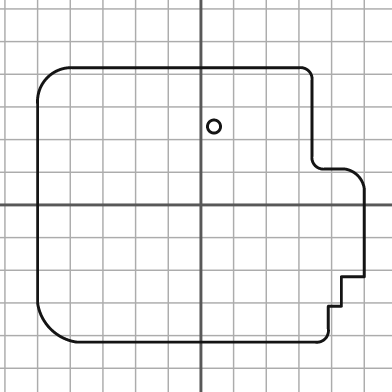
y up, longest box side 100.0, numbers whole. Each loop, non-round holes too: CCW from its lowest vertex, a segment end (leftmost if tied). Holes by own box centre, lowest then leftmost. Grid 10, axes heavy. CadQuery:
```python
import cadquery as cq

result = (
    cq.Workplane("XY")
    .moveTo(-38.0, -42.0)
    .lineTo(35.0, -42.0)
    .threePointArc((38.0, -41.0), (39.0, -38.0))
    .lineTo(39.0, -31.0)
    .lineTo(43.0, -31.0)
    .lineTo(43.0, -22.0)
    .lineTo(50.0, -22.0)
    .lineTo(50.0, 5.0)
    .threePointArc((48.0, 9.0), (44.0, 11.0))
    .lineTo(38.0, 11.0)
    .threePointArc((35.0, 12.0), (34.0, 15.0))
    .lineTo(34.0, 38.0)
    .threePointArc((33.0, 41.0), (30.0, 42.0))
    .lineTo(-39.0, 42.0)
    .threePointArc((-47.0, 39.0), (-50.0, 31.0))
    .lineTo(-50.0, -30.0)
    .threePointArc((-46.0, -38.0), (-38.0, -42.0))
    .close()
    .moveTo(4.0, 24.0)
    .circle(2.0)
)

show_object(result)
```